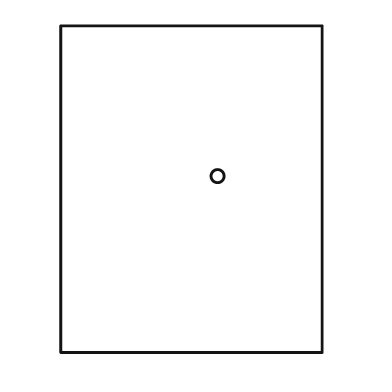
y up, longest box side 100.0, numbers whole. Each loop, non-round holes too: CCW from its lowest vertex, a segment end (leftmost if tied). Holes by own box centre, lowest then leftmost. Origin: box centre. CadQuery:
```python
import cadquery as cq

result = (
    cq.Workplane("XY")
    .moveTo(-40.0, -50.0)
    .lineTo(40.0, -50.0)
    .lineTo(40.0, 50.0)
    .lineTo(-40.0, 50.0)
    .close()
    .moveTo(8.0, 4.0)
    .circle(2.0)
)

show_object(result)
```